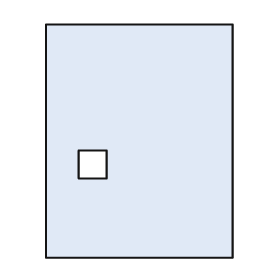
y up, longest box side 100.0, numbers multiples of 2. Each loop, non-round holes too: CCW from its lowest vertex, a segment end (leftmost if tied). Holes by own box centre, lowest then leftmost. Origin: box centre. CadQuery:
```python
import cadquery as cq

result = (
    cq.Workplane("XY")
    .moveTo(-40.0, -50.0)
    .lineTo(40.0, -50.0)
    .lineTo(40.0, 50.0)
    .lineTo(-40.0, 50.0)
    .close()
    .moveTo(-26.0, -16.0)
    .lineTo(-14.0, -16.0)
    .lineTo(-14.0, -4.0)
    .lineTo(-26.0, -4.0)
    .close()
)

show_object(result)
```